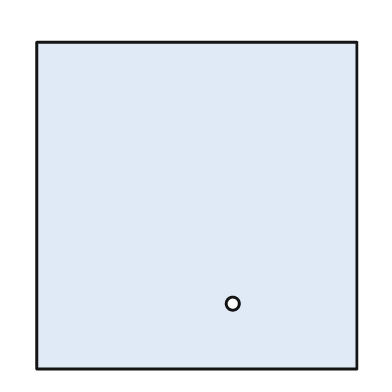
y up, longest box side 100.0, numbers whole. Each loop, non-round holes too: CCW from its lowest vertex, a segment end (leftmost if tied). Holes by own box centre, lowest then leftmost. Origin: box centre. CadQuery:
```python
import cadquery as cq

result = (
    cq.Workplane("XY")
    .moveTo(-49.0, -50.0)
    .lineTo(49.0, -50.0)
    .lineTo(49.0, 50.0)
    .lineTo(-49.0, 50.0)
    .close()
    .moveTo(11.0, -30.0)
    .circle(2.0)
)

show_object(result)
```